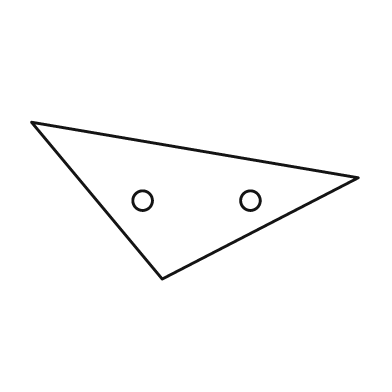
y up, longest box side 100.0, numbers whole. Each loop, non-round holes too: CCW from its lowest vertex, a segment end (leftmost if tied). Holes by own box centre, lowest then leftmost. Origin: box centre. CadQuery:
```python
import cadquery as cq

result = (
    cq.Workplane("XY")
    .moveTo(-10.0, -24.0)
    .lineTo(50.0, 7.0)
    .lineTo(-50.0, 24.0)
    .close()
    .moveTo(-16.0, 0.0)
    .circle(3.0)
    .moveTo(17.0, 0.0)
    .circle(3.0)
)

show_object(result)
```